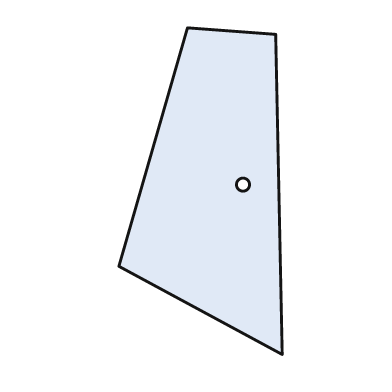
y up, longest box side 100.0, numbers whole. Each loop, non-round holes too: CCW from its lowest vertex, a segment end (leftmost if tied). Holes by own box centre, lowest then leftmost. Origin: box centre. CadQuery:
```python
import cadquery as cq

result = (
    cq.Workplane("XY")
    .moveTo(25.0, -50.0)
    .lineTo(23.0, 48.0)
    .lineTo(-4.0, 50.0)
    .lineTo(-25.0, -23.0)
    .close()
    .moveTo(13.0, 2.0)
    .circle(2.0)
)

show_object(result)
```